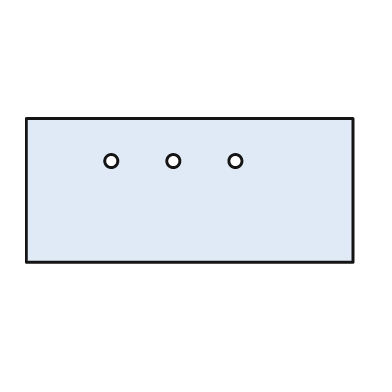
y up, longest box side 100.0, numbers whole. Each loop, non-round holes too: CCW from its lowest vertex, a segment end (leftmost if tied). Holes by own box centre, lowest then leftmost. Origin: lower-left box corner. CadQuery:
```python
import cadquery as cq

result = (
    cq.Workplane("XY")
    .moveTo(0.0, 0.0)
    .lineTo(100.0, 0.0)
    .lineTo(100.0, 44.0)
    .lineTo(0.0, 44.0)
    .close()
    .moveTo(26.0, 31.0)
    .circle(2.0)
    .moveTo(45.0, 31.0)
    .circle(2.0)
    .moveTo(64.0, 31.0)
    .circle(2.0)
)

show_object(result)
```